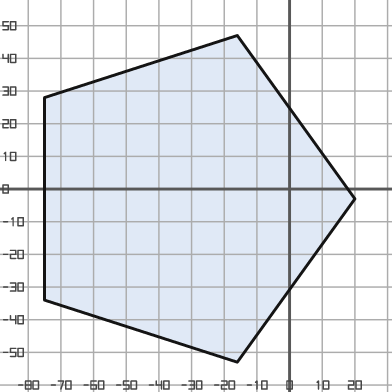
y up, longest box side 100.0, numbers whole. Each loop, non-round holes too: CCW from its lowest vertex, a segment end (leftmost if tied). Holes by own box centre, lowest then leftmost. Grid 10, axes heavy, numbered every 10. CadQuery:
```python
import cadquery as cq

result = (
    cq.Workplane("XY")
    .moveTo(-16.0, -53.0)
    .lineTo(20.0, -3.0)
    .lineTo(-16.0, 47.0)
    .lineTo(-75.0, 28.0)
    .lineTo(-75.0, -34.0)
    .close()
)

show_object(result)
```